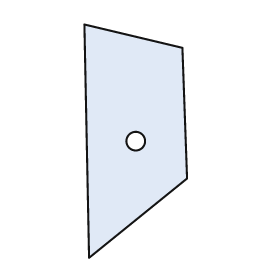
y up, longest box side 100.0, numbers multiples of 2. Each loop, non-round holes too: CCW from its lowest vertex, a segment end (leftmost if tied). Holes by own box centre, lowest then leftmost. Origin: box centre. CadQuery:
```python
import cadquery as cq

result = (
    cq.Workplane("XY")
    .moveTo(-20.0, -50.0)
    .lineTo(22.0, -16.0)
    .lineTo(20.0, 40.0)
    .lineTo(-22.0, 50.0)
    .close()
    .moveTo(0.0, 0.0)
    .circle(4.0)
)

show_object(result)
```